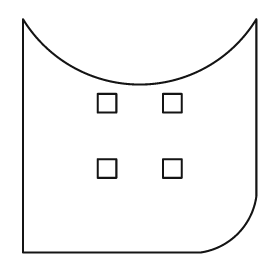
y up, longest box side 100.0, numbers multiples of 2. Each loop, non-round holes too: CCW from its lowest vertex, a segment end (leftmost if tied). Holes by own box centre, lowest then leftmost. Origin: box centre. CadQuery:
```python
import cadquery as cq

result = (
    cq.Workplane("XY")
    .moveTo(-50.0, -50.0)
    .lineTo(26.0, -50.0)
    .threePointArc((42.0, -42.0), (50.0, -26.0))
    .lineTo(50.0, 50.0)
    .threePointArc((0.0, 22.0), (-50.0, 50.0))
    .close()
    .moveTo(-18.0, -18.0)
    .lineTo(-10.0, -18.0)
    .lineTo(-10.0, -10.0)
    .lineTo(-18.0, -10.0)
    .close()
    .moveTo(10.0, -18.0)
    .lineTo(18.0, -18.0)
    .lineTo(18.0, -10.0)
    .lineTo(10.0, -10.0)
    .close()
    .moveTo(-18.0, 10.0)
    .lineTo(-10.0, 10.0)
    .lineTo(-10.0, 18.0)
    .lineTo(-18.0, 18.0)
    .close()
    .moveTo(10.0, 10.0)
    .lineTo(18.0, 10.0)
    .lineTo(18.0, 18.0)
    .lineTo(10.0, 18.0)
    .close()
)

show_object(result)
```